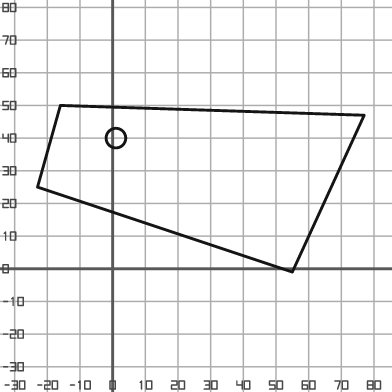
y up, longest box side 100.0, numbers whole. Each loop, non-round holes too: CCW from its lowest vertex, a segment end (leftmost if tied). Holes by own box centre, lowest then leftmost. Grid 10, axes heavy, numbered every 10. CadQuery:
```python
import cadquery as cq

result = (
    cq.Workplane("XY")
    .moveTo(55.0, -1.0)
    .lineTo(77.0, 47.0)
    .lineTo(-16.0, 50.0)
    .lineTo(-23.0, 25.0)
    .close()
    .moveTo(1.0, 40.0)
    .circle(3.0)
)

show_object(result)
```